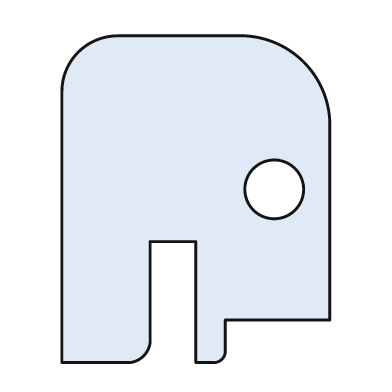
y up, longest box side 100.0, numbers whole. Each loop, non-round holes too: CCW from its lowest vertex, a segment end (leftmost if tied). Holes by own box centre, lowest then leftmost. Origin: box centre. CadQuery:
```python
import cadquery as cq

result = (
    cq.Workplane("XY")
    .moveTo(-41.0, -50.0)
    .lineTo(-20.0, -50.0)
    .threePointArc((-16.0, -48.0), (-14.0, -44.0))
    .lineTo(-14.0, -13.0)
    .lineTo(0.0, -13.0)
    .lineTo(0.0, -50.0)
    .lineTo(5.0, -50.0)
    .threePointArc((8.0, -49.0), (9.0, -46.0))
    .lineTo(9.0, -37.0)
    .lineTo(41.0, -37.0)
    .lineTo(41.0, 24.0)
    .threePointArc((33.0, 42.0), (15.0, 50.0))
    .lineTo(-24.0, 50.0)
    .threePointArc((-36.0, 45.0), (-41.0, 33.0))
    .close()
    .moveTo(24.0, 3.0)
    .circle(9.0)
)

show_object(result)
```